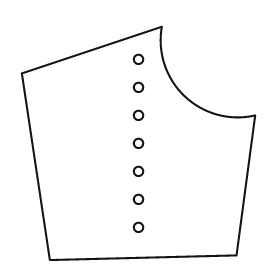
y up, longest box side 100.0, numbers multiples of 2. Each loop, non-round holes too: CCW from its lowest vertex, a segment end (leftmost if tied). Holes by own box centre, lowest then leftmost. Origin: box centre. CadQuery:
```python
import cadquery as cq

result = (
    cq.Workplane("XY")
    .moveTo(-38.0, -50.0)
    .lineTo(42.0, -48.0)
    .lineTo(50.0, 12.0)
    .threePointArc((20.0, 20.0), (10.0, 50.0))
    .lineTo(-50.0, 30.0)
    .close()
    .moveTo(0.0, -36.0)
    .circle(2.0)
    .moveTo(0.0, -24.0)
    .circle(2.0)
    .moveTo(0.0, -12.0)
    .circle(2.0)
    .moveTo(0.0, 0.0)
    .circle(2.0)
    .moveTo(0.0, 12.0)
    .circle(2.0)
    .moveTo(0.0, 24.0)
    .circle(2.0)
    .moveTo(0.0, 36.0)
    .circle(2.0)
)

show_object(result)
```